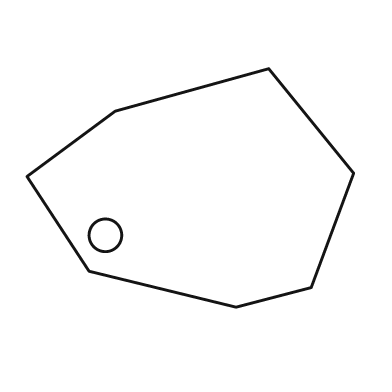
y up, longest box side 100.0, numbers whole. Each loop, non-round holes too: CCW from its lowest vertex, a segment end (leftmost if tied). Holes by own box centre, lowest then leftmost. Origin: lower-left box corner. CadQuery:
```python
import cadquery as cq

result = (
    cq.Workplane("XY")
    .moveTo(64.0, 0.0)
    .lineTo(87.0, 6.0)
    .lineTo(100.0, 41.0)
    .lineTo(74.0, 73.0)
    .lineTo(27.0, 60.0)
    .lineTo(0.0, 40.0)
    .lineTo(19.0, 11.0)
    .close()
    .moveTo(24.0, 22.0)
    .circle(5.0)
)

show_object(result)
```